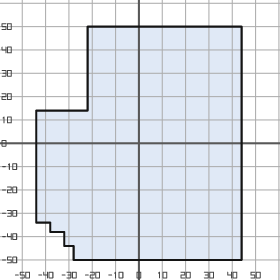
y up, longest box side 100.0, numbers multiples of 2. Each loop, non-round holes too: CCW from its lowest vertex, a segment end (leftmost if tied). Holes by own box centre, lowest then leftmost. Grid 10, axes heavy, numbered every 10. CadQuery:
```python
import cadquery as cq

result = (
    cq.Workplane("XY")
    .moveTo(-28.0, -50.0)
    .lineTo(44.0, -50.0)
    .lineTo(44.0, 50.0)
    .lineTo(-22.0, 50.0)
    .lineTo(-22.0, 14.0)
    .lineTo(-44.0, 14.0)
    .lineTo(-44.0, -34.0)
    .lineTo(-38.0, -34.0)
    .lineTo(-38.0, -38.0)
    .lineTo(-32.0, -38.0)
    .lineTo(-32.0, -44.0)
    .lineTo(-28.0, -44.0)
    .close()
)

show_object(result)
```